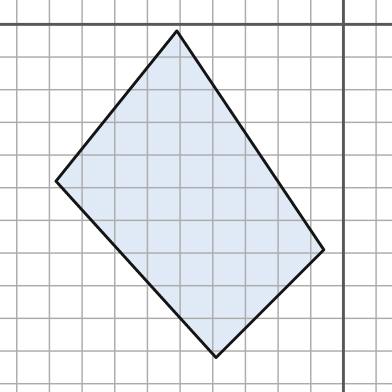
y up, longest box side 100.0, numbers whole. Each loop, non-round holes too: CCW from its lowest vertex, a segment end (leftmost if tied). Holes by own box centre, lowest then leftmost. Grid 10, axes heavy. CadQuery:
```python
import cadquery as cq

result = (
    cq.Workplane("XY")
    .moveTo(-39.0, -102.0)
    .lineTo(-6.0, -69.0)
    .lineTo(-51.0, -2.0)
    .lineTo(-88.0, -48.0)
    .close()
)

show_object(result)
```